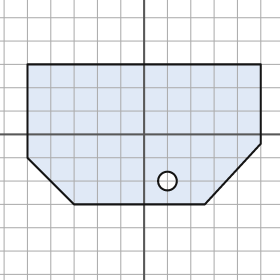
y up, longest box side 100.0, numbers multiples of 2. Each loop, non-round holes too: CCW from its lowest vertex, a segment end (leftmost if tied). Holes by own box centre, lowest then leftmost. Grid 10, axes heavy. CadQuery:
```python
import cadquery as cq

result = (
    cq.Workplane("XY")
    .moveTo(-30.0, -30.0)
    .lineTo(26.0, -30.0)
    .lineTo(50.0, -4.0)
    .lineTo(50.0, 30.0)
    .lineTo(-50.0, 30.0)
    .lineTo(-50.0, -10.0)
    .close()
    .moveTo(10.0, -20.0)
    .circle(4.0)
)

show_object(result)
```